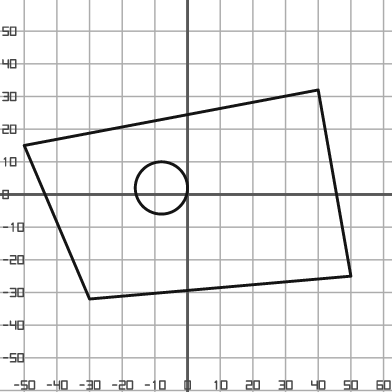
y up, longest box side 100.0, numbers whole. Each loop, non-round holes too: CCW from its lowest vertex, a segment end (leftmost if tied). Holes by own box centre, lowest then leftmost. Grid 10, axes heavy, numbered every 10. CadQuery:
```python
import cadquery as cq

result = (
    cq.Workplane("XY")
    .moveTo(-30.0, -32.0)
    .lineTo(50.0, -25.0)
    .lineTo(40.0, 32.0)
    .lineTo(-50.0, 15.0)
    .close()
    .moveTo(-8.0, 2.0)
    .circle(8.0)
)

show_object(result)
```